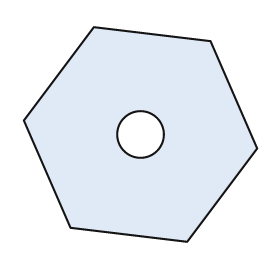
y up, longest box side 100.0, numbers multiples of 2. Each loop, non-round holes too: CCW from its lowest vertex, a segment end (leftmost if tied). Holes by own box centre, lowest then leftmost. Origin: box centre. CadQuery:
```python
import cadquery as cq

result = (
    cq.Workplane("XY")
    .moveTo(20.0, -46.0)
    .lineTo(50.0, -6.0)
    .lineTo(30.0, 40.0)
    .lineTo(-20.0, 46.0)
    .lineTo(-50.0, 6.0)
    .lineTo(-30.0, -40.0)
    .close()
    .moveTo(0.0, 0.0)
    .circle(10.0)
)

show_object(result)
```